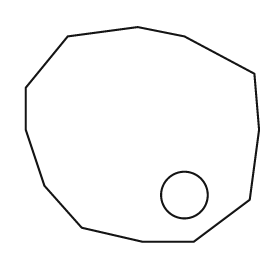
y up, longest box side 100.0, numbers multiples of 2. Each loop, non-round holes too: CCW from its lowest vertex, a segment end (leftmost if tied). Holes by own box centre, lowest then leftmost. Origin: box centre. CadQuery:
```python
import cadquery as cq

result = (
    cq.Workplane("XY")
    .moveTo(0.0, -46.0)
    .lineTo(22.0, -46.0)
    .lineTo(46.0, -28.0)
    .lineTo(50.0, 2.0)
    .lineTo(48.0, 26.0)
    .lineTo(18.0, 42.0)
    .lineTo(-2.0, 46.0)
    .lineTo(-32.0, 42.0)
    .lineTo(-50.0, 20.0)
    .lineTo(-50.0, 2.0)
    .lineTo(-42.0, -22.0)
    .lineTo(-26.0, -40.0)
    .close()
    .moveTo(18.0, -26.0)
    .circle(10.0)
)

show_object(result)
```